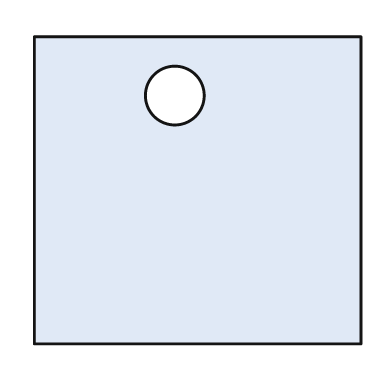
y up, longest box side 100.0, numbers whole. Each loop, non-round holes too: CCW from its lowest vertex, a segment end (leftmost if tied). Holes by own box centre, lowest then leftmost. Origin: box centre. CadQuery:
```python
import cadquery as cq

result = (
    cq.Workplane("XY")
    .moveTo(-50.0, -47.0)
    .lineTo(50.0, -47.0)
    .lineTo(50.0, 47.0)
    .lineTo(-50.0, 47.0)
    .close()
    .moveTo(-7.0, 29.0)
    .circle(9.0)
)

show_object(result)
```